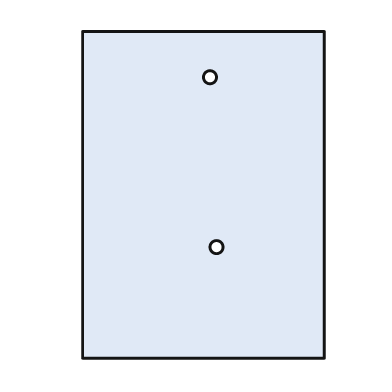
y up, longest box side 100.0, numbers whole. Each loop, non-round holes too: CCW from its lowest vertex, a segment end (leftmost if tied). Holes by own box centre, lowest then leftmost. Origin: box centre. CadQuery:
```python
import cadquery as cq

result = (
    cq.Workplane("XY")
    .moveTo(-37.0, -50.0)
    .lineTo(37.0, -50.0)
    .lineTo(37.0, 50.0)
    .lineTo(-37.0, 50.0)
    .close()
    .moveTo(4.0, -16.0)
    .circle(2.0)
    .moveTo(2.0, 36.0)
    .circle(2.0)
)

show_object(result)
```